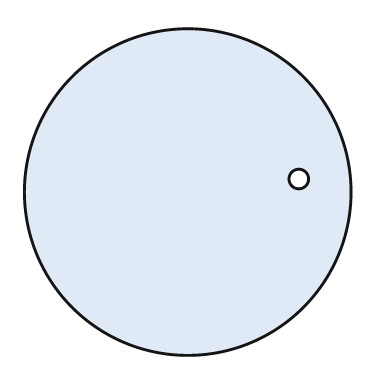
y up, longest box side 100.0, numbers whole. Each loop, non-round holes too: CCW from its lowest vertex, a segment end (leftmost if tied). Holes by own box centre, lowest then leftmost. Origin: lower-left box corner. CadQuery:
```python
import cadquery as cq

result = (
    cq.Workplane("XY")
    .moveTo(50.0, 50.0)
    .circle(50.0)
    .moveTo(84.0, 54.0)
    .circle(3.0)
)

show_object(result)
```